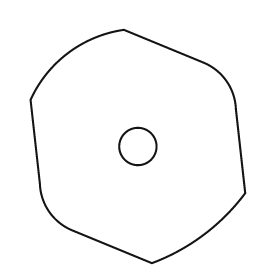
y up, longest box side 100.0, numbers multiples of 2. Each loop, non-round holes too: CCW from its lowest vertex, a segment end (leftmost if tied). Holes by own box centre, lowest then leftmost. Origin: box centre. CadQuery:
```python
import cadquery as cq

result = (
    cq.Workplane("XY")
    .moveTo(6.0, -50.0)
    .threePointArc((28.0, -38.0), (46.0, -20.0))
    .lineTo(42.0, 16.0)
    .threePointArc((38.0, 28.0), (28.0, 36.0))
    .lineTo(-6.0, 50.0)
    .threePointArc((-30.0, 40.0), (-46.0, 20.0))
    .lineTo(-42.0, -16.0)
    .threePointArc((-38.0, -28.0), (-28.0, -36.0))
    .close()
    .moveTo(0.0, 0.0)
    .circle(8.0)
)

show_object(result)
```